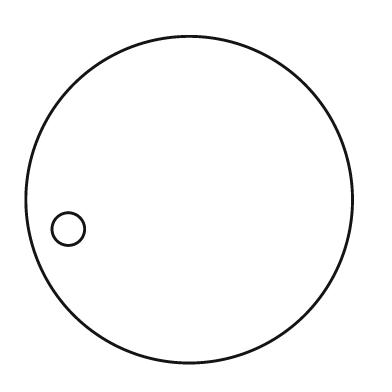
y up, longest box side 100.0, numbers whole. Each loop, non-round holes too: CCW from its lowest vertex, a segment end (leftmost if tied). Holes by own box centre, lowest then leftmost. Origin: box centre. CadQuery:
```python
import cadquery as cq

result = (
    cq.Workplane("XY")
    .moveTo(0.0, 0.0)
    .circle(50.0)
    .moveTo(-37.0, -9.0)
    .circle(5.0)
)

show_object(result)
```